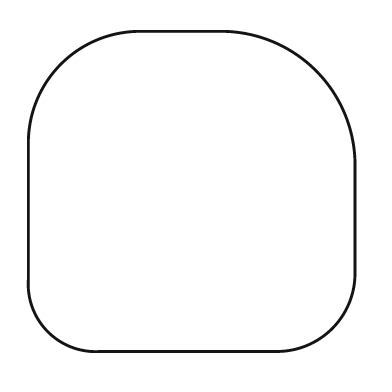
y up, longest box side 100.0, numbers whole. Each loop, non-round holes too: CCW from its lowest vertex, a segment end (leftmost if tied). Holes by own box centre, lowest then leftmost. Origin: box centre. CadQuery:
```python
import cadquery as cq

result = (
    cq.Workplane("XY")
    .moveTo(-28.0, -49.0)
    .lineTo(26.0, -49.0)
    .threePointArc((43.0, -42.0), (50.0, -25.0))
    .lineTo(50.0, 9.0)
    .threePointArc((38.0, 37.0), (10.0, 49.0))
    .lineTo(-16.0, 49.0)
    .threePointArc((-40.0, 39.0), (-50.0, 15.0))
    .lineTo(-50.0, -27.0)
    .threePointArc((-44.0, -43.0), (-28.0, -49.0))
    .close()
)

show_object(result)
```